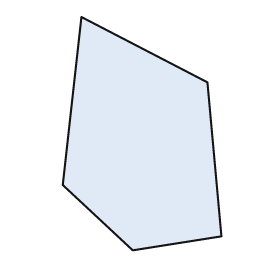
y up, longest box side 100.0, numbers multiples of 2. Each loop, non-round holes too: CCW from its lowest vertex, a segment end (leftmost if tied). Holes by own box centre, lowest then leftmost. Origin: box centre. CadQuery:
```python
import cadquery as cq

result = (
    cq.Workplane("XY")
    .moveTo(-4.0, -50.0)
    .lineTo(34.0, -44.0)
    .lineTo(28.0, 22.0)
    .lineTo(-26.0, 50.0)
    .lineTo(-34.0, -22.0)
    .close()
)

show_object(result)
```